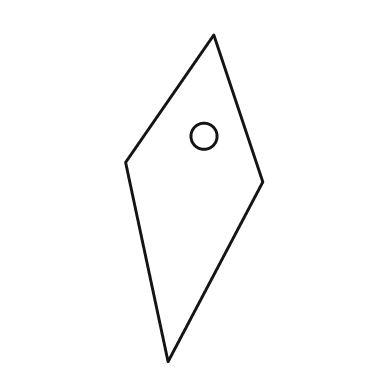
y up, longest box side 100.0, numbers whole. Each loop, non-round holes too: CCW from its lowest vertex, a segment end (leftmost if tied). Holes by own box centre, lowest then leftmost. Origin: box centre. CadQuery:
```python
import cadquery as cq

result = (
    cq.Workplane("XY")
    .moveTo(-8.0, -50.0)
    .lineTo(21.0, 5.0)
    .lineTo(6.0, 50.0)
    .lineTo(-21.0, 11.0)
    .close()
    .moveTo(3.0, 19.0)
    .circle(4.0)
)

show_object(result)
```